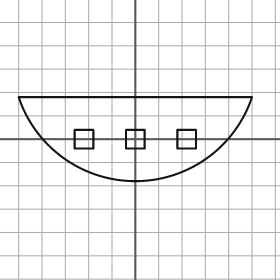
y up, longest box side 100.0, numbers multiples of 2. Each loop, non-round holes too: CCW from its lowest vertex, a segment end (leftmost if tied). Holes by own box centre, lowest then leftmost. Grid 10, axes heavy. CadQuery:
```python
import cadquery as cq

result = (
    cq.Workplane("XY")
    .moveTo(-50.0, 18.0)
    .threePointArc((0.0, -18.0), (50.0, 18.0))
    .close()
    .moveTo(-26.0, -4.0)
    .lineTo(-18.0, -4.0)
    .lineTo(-18.0, 4.0)
    .lineTo(-26.0, 4.0)
    .close()
    .moveTo(-4.0, -4.0)
    .lineTo(4.0, -4.0)
    .lineTo(4.0, 4.0)
    .lineTo(-4.0, 4.0)
    .close()
    .moveTo(18.0, -4.0)
    .lineTo(26.0, -4.0)
    .lineTo(26.0, 4.0)
    .lineTo(18.0, 4.0)
    .close()
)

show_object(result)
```